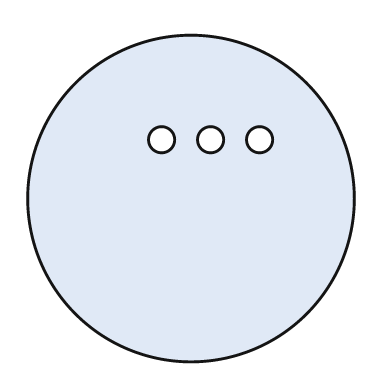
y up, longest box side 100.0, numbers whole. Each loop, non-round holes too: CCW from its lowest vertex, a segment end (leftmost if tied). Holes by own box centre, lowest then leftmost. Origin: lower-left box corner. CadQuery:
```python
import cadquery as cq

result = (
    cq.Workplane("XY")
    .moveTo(50.0, 50.0)
    .circle(50.0)
    .moveTo(41.0, 68.0)
    .circle(4.0)
    .moveTo(56.0, 68.0)
    .circle(4.0)
    .moveTo(71.0, 68.0)
    .circle(4.0)
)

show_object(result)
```